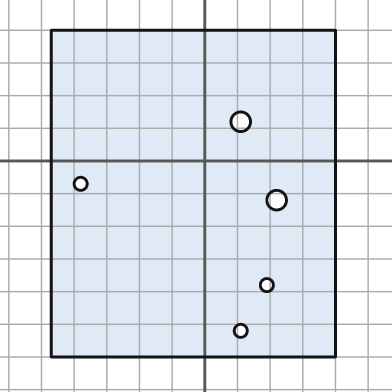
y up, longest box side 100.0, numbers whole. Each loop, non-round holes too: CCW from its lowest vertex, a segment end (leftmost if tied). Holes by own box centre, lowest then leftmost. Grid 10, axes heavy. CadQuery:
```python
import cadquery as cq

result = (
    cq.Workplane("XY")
    .moveTo(-47.0, -60.0)
    .lineTo(40.0, -60.0)
    .lineTo(40.0, 40.0)
    .lineTo(-47.0, 40.0)
    .close()
    .moveTo(11.0, -52.0)
    .circle(2.0)
    .moveTo(19.0, -38.0)
    .circle(2.0)
    .moveTo(22.0, -12.0)
    .circle(3.0)
    .moveTo(-38.0, -7.0)
    .circle(2.0)
    .moveTo(11.0, 12.0)
    .circle(3.0)
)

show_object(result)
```